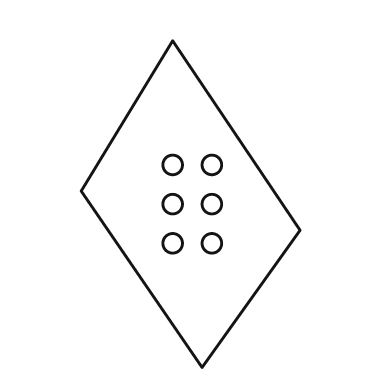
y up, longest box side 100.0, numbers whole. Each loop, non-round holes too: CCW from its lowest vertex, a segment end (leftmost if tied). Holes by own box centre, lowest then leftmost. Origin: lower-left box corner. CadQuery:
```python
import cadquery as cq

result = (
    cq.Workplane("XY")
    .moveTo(37.0, 0.0)
    .lineTo(67.0, 42.0)
    .lineTo(28.0, 100.0)
    .lineTo(0.0, 54.0)
    .close()
    .moveTo(28.0, 38.0)
    .circle(3.0)
    .moveTo(40.0, 38.0)
    .circle(3.0)
    .moveTo(28.0, 50.0)
    .circle(3.0)
    .moveTo(40.0, 50.0)
    .circle(3.0)
    .moveTo(28.0, 62.0)
    .circle(3.0)
    .moveTo(40.0, 62.0)
    .circle(3.0)
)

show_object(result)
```